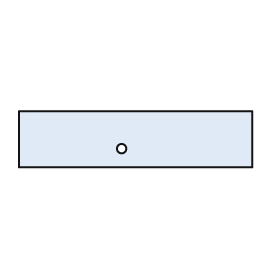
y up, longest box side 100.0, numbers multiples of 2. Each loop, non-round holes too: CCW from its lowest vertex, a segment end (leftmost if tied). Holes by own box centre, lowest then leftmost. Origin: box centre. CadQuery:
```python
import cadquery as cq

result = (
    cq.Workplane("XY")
    .moveTo(-50.0, -12.0)
    .lineTo(50.0, -12.0)
    .lineTo(50.0, 12.0)
    .lineTo(-50.0, 12.0)
    .close()
    .moveTo(-6.0, -4.0)
    .circle(2.0)
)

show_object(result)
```